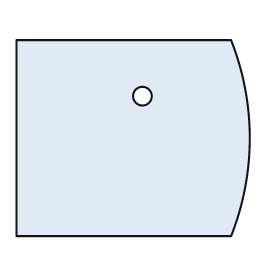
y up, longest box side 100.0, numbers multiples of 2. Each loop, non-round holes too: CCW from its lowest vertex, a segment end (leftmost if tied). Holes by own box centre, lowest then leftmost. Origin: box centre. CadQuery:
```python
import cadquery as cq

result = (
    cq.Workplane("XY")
    .moveTo(-50.0, -42.0)
    .lineTo(42.0, -42.0)
    .threePointArc((50.0, 0.0), (42.0, 42.0))
    .lineTo(-50.0, 42.0)
    .close()
    .moveTo(4.0, 18.0)
    .circle(4.0)
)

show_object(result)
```